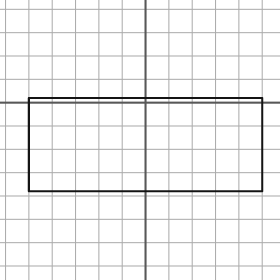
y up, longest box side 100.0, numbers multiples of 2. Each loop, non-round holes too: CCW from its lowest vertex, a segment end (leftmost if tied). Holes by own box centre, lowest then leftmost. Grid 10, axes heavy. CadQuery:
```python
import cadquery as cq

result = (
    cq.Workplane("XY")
    .moveTo(-50.0, -38.0)
    .lineTo(50.0, -38.0)
    .lineTo(50.0, 2.0)
    .lineTo(-50.0, 2.0)
    .close()
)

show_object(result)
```